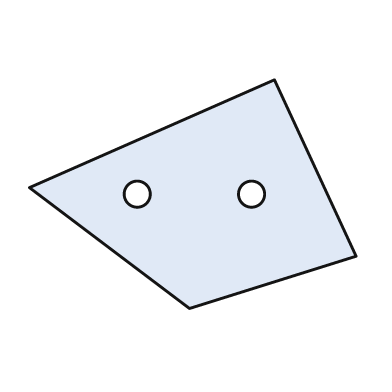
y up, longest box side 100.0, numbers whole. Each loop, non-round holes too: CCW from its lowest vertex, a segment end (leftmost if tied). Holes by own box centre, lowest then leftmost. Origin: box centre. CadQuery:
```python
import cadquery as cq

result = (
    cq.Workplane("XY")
    .moveTo(-1.0, -35.0)
    .lineTo(50.0, -19.0)
    .lineTo(25.0, 35.0)
    .lineTo(-50.0, 2.0)
    .close()
    .moveTo(-17.0, 0.0)
    .circle(4.0)
    .moveTo(18.0, 0.0)
    .circle(4.0)
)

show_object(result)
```